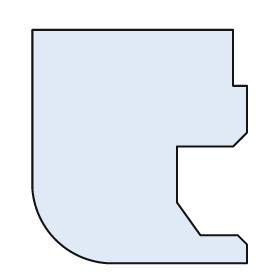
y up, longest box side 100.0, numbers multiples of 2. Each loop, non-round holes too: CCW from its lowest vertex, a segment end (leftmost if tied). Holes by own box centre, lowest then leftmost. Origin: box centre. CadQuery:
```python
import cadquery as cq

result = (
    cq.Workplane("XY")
    .moveTo(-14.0, -50.0)
    .lineTo(46.0, -50.0)
    .lineTo(46.0, -42.0)
    .lineTo(42.0, -38.0)
    .lineTo(26.0, -38.0)
    .lineTo(16.0, -24.0)
    .lineTo(16.0, 0.0)
    .lineTo(40.0, 0.0)
    .lineTo(46.0, 6.0)
    .lineTo(46.0, 26.0)
    .lineTo(40.0, 26.0)
    .lineTo(40.0, 50.0)
    .lineTo(-46.0, 50.0)
    .lineTo(-46.0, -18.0)
    .threePointArc((-36.0, -40.0), (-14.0, -50.0))
    .close()
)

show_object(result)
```